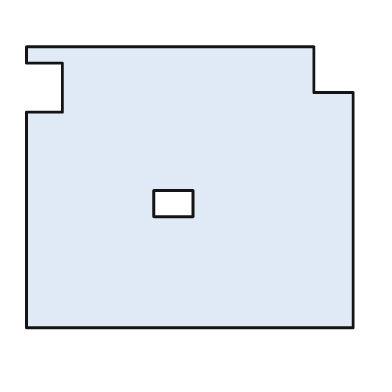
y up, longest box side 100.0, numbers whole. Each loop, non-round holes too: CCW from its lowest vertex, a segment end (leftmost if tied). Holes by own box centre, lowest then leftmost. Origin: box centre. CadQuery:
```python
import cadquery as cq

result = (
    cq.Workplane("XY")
    .moveTo(-50.0, -43.0)
    .lineTo(50.0, -43.0)
    .lineTo(50.0, 29.0)
    .lineTo(38.0, 29.0)
    .lineTo(38.0, 43.0)
    .lineTo(-50.0, 43.0)
    .lineTo(-50.0, 38.0)
    .lineTo(-39.0, 38.0)
    .lineTo(-39.0, 23.0)
    .lineTo(-50.0, 23.0)
    .close()
    .moveTo(-11.0, -9.0)
    .lineTo(1.0, -9.0)
    .lineTo(1.0, -1.0)
    .lineTo(-11.0, -1.0)
    .close()
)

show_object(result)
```